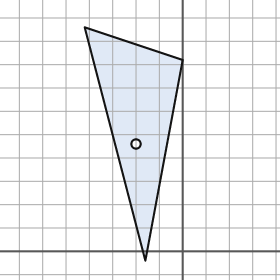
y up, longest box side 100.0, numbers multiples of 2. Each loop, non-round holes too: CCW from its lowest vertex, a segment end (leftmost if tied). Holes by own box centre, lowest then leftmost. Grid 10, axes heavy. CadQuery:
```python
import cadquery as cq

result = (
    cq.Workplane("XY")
    .moveTo(-16.0, -4.0)
    .lineTo(0.0, 82.0)
    .lineTo(-42.0, 96.0)
    .close()
    .moveTo(-20.0, 46.0)
    .circle(2.0)
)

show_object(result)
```